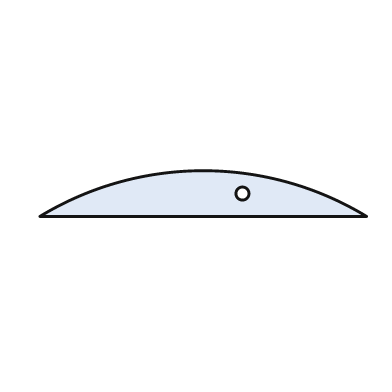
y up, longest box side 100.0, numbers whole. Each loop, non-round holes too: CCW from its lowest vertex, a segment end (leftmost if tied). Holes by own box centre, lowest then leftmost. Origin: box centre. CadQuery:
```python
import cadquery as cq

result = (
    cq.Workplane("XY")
    .moveTo(-50.0, -7.0)
    .lineTo(50.0, -7.0)
    .threePointArc((0.0, 7.0), (-50.0, -7.0))
    .close()
    .moveTo(12.0, 0.0)
    .circle(2.0)
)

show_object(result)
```